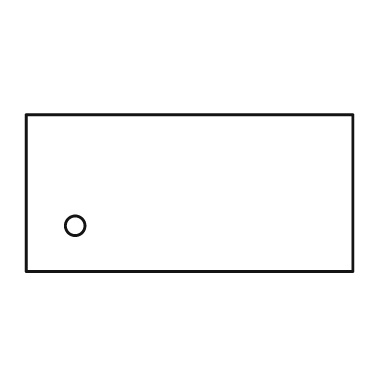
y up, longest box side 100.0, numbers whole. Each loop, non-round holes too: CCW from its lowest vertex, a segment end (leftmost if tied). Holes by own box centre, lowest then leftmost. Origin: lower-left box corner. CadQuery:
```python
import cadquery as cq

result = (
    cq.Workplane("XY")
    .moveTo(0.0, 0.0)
    .lineTo(100.0, 0.0)
    .lineTo(100.0, 48.0)
    .lineTo(0.0, 48.0)
    .close()
    .moveTo(15.0, 14.0)
    .circle(3.0)
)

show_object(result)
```